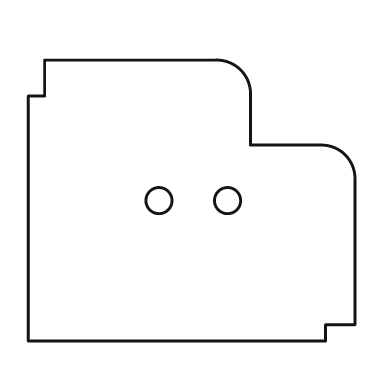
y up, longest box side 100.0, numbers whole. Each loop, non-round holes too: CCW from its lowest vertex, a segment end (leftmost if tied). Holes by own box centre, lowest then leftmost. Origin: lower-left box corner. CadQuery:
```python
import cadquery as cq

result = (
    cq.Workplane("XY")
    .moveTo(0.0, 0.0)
    .lineTo(91.0, 0.0)
    .lineTo(91.0, 5.0)
    .lineTo(100.0, 5.0)
    .lineTo(100.0, 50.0)
    .threePointArc((97.0, 57.0), (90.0, 60.0))
    .lineTo(68.0, 60.0)
    .lineTo(68.0, 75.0)
    .threePointArc((65.0, 83.0), (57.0, 86.0))
    .lineTo(5.0, 86.0)
    .lineTo(5.0, 75.0)
    .lineTo(0.0, 75.0)
    .close()
    .moveTo(40.0, 43.0)
    .circle(4.0)
    .moveTo(61.0, 43.0)
    .circle(4.0)
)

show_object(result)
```